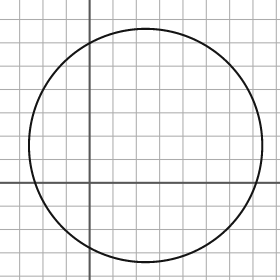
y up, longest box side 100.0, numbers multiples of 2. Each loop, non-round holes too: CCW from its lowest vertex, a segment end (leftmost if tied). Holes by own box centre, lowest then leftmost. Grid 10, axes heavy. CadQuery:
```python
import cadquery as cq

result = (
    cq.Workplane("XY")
    .moveTo(24.0, 16.0)
    .circle(50.0)
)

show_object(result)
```